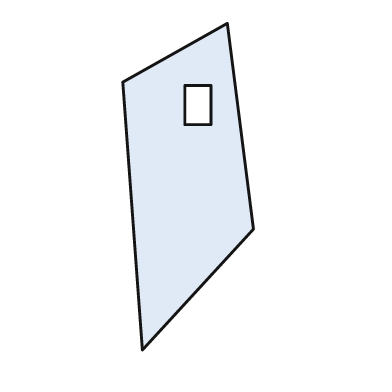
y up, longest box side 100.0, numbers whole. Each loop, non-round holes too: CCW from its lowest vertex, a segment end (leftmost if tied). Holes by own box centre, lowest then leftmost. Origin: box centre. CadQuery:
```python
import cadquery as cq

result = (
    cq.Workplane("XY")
    .moveTo(-14.0, -50.0)
    .lineTo(20.0, -13.0)
    .lineTo(12.0, 50.0)
    .lineTo(-20.0, 32.0)
    .close()
    .moveTo(-1.0, 19.0)
    .lineTo(7.0, 19.0)
    .lineTo(7.0, 31.0)
    .lineTo(-1.0, 31.0)
    .close()
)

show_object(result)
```